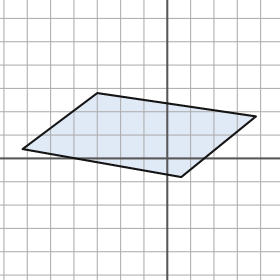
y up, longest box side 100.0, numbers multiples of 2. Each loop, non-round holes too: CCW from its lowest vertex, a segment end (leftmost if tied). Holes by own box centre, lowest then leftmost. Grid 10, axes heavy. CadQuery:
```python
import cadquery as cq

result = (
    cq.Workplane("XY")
    .moveTo(6.0, -8.0)
    .lineTo(38.0, 18.0)
    .lineTo(-30.0, 28.0)
    .lineTo(-62.0, 4.0)
    .close()
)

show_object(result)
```